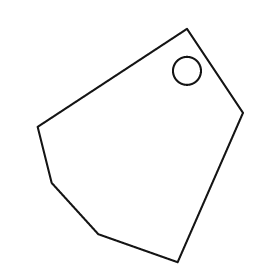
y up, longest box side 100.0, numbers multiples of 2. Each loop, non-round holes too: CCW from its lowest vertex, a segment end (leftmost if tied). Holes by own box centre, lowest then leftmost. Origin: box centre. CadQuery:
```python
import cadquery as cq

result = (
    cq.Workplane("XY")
    .moveTo(16.0, -50.0)
    .lineTo(44.0, 14.0)
    .lineTo(20.0, 50.0)
    .lineTo(-44.0, 8.0)
    .lineTo(-38.0, -16.0)
    .lineTo(-18.0, -38.0)
    .close()
    .moveTo(20.0, 32.0)
    .circle(6.0)
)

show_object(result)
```